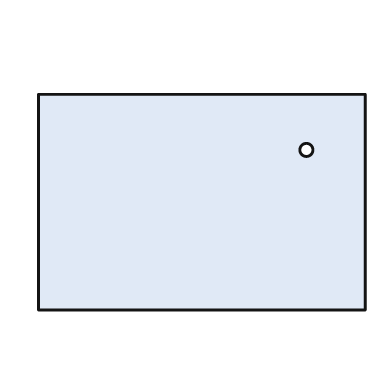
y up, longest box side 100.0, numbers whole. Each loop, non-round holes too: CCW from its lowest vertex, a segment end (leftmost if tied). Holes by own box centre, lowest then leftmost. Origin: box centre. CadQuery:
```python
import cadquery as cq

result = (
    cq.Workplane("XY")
    .moveTo(-50.0, -33.0)
    .lineTo(50.0, -33.0)
    .lineTo(50.0, 33.0)
    .lineTo(-50.0, 33.0)
    .close()
    .moveTo(32.0, 16.0)
    .circle(2.0)
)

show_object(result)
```